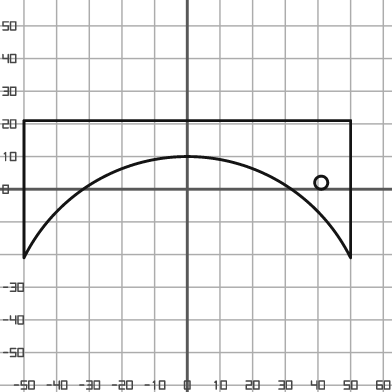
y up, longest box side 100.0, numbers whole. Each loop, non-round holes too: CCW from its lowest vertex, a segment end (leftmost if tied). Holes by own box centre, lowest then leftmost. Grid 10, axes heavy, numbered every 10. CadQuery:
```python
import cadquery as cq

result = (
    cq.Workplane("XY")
    .moveTo(-50.0, -21.0)
    .threePointArc((0.0, 10.0), (50.0, -21.0))
    .lineTo(50.0, 21.0)
    .lineTo(-50.0, 21.0)
    .close()
    .moveTo(41.0, 2.0)
    .circle(2.0)
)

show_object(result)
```